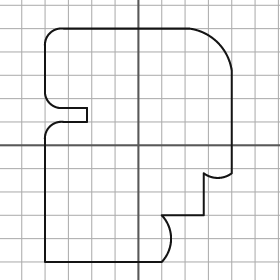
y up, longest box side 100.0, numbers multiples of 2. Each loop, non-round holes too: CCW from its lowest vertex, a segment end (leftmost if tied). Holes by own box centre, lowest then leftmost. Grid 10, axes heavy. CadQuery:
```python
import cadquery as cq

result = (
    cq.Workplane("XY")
    .moveTo(-40.0, -50.0)
    .lineTo(10.0, -50.0)
    .threePointArc((14.0, -40.0), (10.0, -30.0))
    .lineTo(28.0, -30.0)
    .lineTo(28.0, -12.0)
    .threePointArc((34.0, -14.0), (40.0, -12.0))
    .lineTo(40.0, 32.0)
    .threePointArc((34.0, 44.0), (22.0, 50.0))
    .lineTo(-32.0, 50.0)
    .threePointArc((-38.0, 48.0), (-40.0, 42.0))
    .lineTo(-40.0, 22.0)
    .threePointArc((-38.0, 18.0), (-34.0, 16.0))
    .lineTo(-22.0, 16.0)
    .lineTo(-22.0, 10.0)
    .lineTo(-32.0, 10.0)
    .threePointArc((-38.0, 8.0), (-40.0, 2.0))
    .close()
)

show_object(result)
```